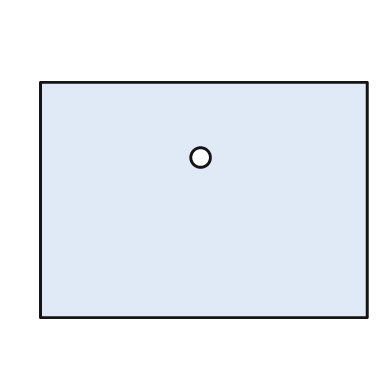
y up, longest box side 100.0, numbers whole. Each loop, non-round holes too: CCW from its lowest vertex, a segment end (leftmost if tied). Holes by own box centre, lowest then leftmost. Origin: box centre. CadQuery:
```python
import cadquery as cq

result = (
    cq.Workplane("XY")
    .moveTo(-50.0, -36.0)
    .lineTo(50.0, -36.0)
    .lineTo(50.0, 36.0)
    .lineTo(-50.0, 36.0)
    .close()
    .moveTo(-1.0, 13.0)
    .circle(3.0)
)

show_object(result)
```